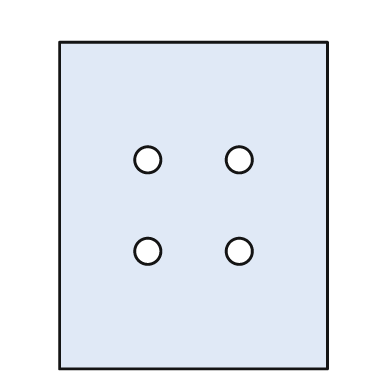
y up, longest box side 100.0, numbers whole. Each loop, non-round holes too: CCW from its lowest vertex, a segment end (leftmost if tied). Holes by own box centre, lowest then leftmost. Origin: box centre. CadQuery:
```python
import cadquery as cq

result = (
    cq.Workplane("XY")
    .moveTo(-41.0, -50.0)
    .lineTo(41.0, -50.0)
    .lineTo(41.0, 50.0)
    .lineTo(-41.0, 50.0)
    .close()
    .moveTo(-14.0, -14.0)
    .circle(4.0)
    .moveTo(14.0, -14.0)
    .circle(4.0)
    .moveTo(-14.0, 14.0)
    .circle(4.0)
    .moveTo(14.0, 14.0)
    .circle(4.0)
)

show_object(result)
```